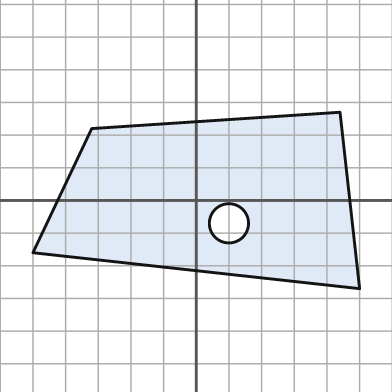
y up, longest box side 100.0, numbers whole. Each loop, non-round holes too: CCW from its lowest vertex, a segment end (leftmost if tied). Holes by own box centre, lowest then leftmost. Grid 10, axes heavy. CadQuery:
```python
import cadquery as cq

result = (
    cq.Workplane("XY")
    .moveTo(50.0, -27.0)
    .lineTo(44.0, 27.0)
    .lineTo(-32.0, 22.0)
    .lineTo(-50.0, -16.0)
    .close()
    .moveTo(10.0, -7.0)
    .circle(6.0)
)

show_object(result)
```